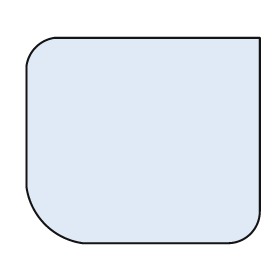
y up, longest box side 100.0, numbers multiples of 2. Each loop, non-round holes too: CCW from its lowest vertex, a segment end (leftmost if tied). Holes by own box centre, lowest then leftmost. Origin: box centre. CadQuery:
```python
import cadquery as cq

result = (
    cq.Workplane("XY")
    .moveTo(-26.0, -44.0)
    .lineTo(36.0, -44.0)
    .threePointArc((46.0, -40.0), (50.0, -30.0))
    .lineTo(50.0, 44.0)
    .lineTo(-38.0, 44.0)
    .threePointArc((-46.0, 40.0), (-50.0, 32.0))
    .lineTo(-50.0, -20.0)
    .threePointArc((-42.0, -36.0), (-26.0, -44.0))
    .close()
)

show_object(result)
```